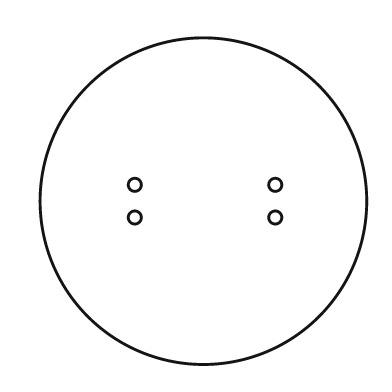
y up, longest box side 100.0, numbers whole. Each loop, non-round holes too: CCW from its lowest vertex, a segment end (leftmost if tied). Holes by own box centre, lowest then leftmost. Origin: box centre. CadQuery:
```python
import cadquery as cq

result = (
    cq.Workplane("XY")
    .moveTo(0.0, 0.0)
    .circle(50.0)
    .moveTo(-21.0, -5.0)
    .circle(2.0)
    .moveTo(22.0, -5.0)
    .circle(2.0)
    .moveTo(-21.0, 5.0)
    .circle(2.0)
    .moveTo(22.0, 5.0)
    .circle(2.0)
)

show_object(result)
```